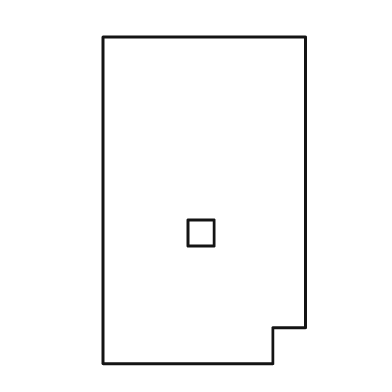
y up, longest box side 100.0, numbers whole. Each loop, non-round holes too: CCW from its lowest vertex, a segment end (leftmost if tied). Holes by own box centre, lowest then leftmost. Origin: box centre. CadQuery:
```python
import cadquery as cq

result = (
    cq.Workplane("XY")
    .moveTo(-31.0, -50.0)
    .lineTo(21.0, -50.0)
    .lineTo(21.0, -39.0)
    .lineTo(31.0, -39.0)
    .lineTo(31.0, 50.0)
    .lineTo(-31.0, 50.0)
    .close()
    .moveTo(-5.0, -14.0)
    .lineTo(3.0, -14.0)
    .lineTo(3.0, -6.0)
    .lineTo(-5.0, -6.0)
    .close()
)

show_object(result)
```